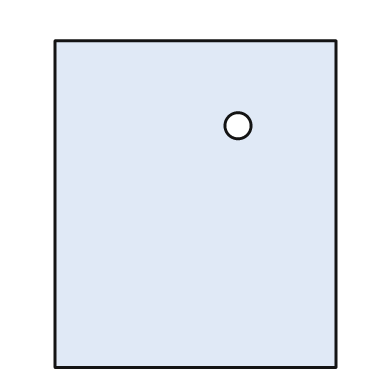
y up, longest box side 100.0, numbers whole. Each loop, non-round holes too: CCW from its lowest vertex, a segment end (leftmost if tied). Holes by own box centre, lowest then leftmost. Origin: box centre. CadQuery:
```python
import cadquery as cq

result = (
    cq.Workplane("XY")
    .moveTo(-43.0, -50.0)
    .lineTo(43.0, -50.0)
    .lineTo(43.0, 50.0)
    .lineTo(-43.0, 50.0)
    .close()
    .moveTo(13.0, 24.0)
    .circle(4.0)
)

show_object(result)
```